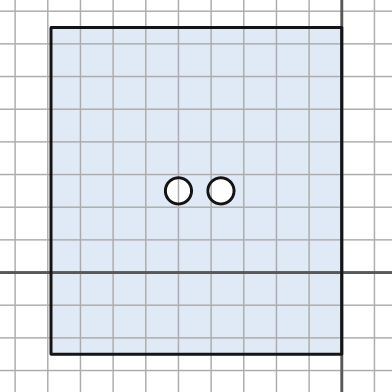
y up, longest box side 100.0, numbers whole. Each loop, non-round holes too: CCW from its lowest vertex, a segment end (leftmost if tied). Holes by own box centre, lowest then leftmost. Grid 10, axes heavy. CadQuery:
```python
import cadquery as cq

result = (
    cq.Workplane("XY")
    .moveTo(-89.0, -25.0)
    .lineTo(0.0, -25.0)
    .lineTo(0.0, 75.0)
    .lineTo(-89.0, 75.0)
    .close()
    .moveTo(-50.0, 25.0)
    .circle(4.0)
    .moveTo(-37.0, 25.0)
    .circle(4.0)
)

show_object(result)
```